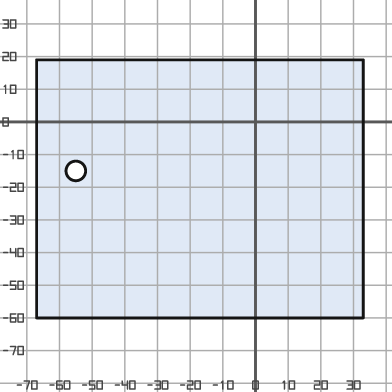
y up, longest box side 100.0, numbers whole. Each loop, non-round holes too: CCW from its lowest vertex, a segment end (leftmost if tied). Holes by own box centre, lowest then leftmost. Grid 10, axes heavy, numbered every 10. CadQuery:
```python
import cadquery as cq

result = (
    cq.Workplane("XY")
    .moveTo(-67.0, -60.0)
    .lineTo(33.0, -60.0)
    .lineTo(33.0, 19.0)
    .lineTo(-67.0, 19.0)
    .close()
    .moveTo(-55.0, -15.0)
    .circle(3.0)
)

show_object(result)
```